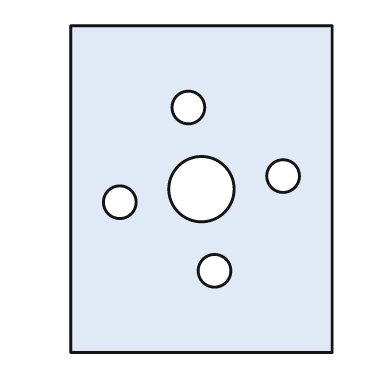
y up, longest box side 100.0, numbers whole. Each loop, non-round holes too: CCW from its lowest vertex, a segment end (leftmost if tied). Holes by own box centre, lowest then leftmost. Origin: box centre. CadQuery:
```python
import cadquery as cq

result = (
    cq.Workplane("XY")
    .moveTo(-40.0, -50.0)
    .lineTo(40.0, -50.0)
    .lineTo(40.0, 50.0)
    .lineTo(-40.0, 50.0)
    .close()
    .moveTo(4.0, -25.0)
    .circle(5.0)
    .moveTo(-25.0, -4.0)
    .circle(5.0)
    .moveTo(0.0, 0.0)
    .circle(10.0)
    .moveTo(25.0, 4.0)
    .circle(5.0)
    .moveTo(-4.0, 25.0)
    .circle(5.0)
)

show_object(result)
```